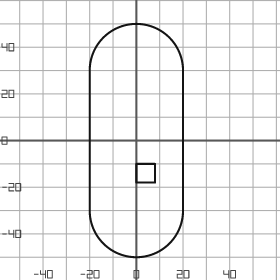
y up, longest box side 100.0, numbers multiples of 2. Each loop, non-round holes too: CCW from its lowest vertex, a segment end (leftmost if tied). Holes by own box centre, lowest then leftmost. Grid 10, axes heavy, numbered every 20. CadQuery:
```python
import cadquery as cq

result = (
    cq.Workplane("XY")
    .moveTo(-20.0, -30.0)
    .threePointArc((0.0, -50.0), (20.0, -30.0))
    .lineTo(20.0, 30.0)
    .threePointArc((0.0, 50.0), (-20.0, 30.0))
    .close()
    .moveTo(0.0, -18.0)
    .lineTo(8.0, -18.0)
    .lineTo(8.0, -10.0)
    .lineTo(0.0, -10.0)
    .close()
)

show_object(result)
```